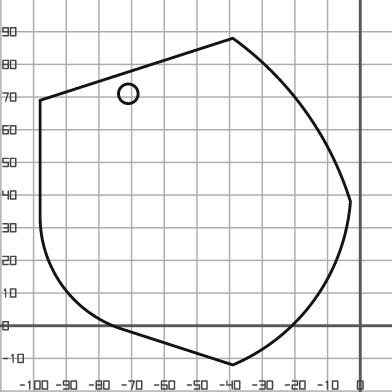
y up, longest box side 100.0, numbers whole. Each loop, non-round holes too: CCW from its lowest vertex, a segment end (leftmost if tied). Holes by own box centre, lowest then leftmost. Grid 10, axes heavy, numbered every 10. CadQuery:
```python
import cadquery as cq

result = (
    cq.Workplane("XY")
    .moveTo(-39.0, -12.0)
    .threePointArc((-14.0, 8.0), (-3.0, 38.0))
    .threePointArc((-17.0, 66.0), (-39.0, 88.0))
    .lineTo(-98.0, 69.0)
    .lineTo(-98.0, 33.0)
    .threePointArc((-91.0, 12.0), (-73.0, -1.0))
    .close()
    .moveTo(-71.0, 71.0)
    .circle(3.0)
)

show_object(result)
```